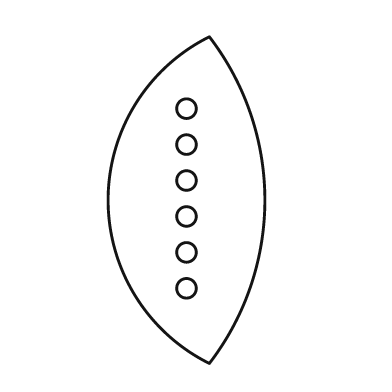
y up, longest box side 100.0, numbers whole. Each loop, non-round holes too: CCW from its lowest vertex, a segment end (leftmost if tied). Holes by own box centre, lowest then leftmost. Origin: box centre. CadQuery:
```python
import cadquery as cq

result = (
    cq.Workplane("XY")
    .moveTo(7.0, -50.0)
    .threePointArc((24.0, 0.0), (7.0, 50.0))
    .threePointArc((-24.0, 0.0), (7.0, -50.0))
    .close()
    .moveTo(0.0, -27.0)
    .circle(3.0)
    .moveTo(0.0, -16.0)
    .circle(3.0)
    .moveTo(0.0, -5.0)
    .circle(3.0)
    .moveTo(0.0, 6.0)
    .circle(3.0)
    .moveTo(0.0, 17.0)
    .circle(3.0)
    .moveTo(0.0, 28.0)
    .circle(3.0)
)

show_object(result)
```